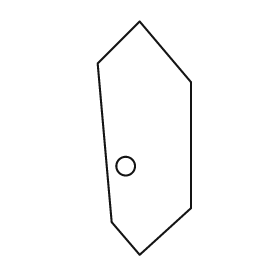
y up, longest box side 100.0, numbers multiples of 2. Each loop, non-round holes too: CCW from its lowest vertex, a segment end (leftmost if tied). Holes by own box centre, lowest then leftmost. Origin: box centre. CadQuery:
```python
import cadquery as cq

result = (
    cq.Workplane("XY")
    .moveTo(-2.0, -50.0)
    .lineTo(20.0, -30.0)
    .lineTo(20.0, 24.0)
    .lineTo(-2.0, 50.0)
    .lineTo(-20.0, 32.0)
    .lineTo(-14.0, -36.0)
    .close()
    .moveTo(-8.0, -12.0)
    .circle(4.0)
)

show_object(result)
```